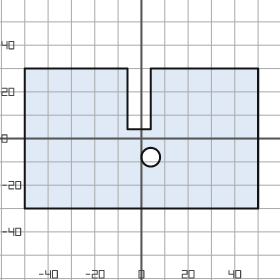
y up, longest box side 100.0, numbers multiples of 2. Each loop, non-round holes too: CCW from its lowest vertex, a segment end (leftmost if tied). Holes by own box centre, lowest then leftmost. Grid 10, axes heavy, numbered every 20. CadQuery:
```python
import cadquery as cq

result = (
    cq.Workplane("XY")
    .moveTo(-50.0, -30.0)
    .lineTo(50.0, -30.0)
    .lineTo(50.0, 30.0)
    .lineTo(4.0, 30.0)
    .lineTo(4.0, 4.0)
    .lineTo(-6.0, 4.0)
    .lineTo(-6.0, 30.0)
    .lineTo(-50.0, 30.0)
    .close()
    .moveTo(4.0, -8.0)
    .circle(4.0)
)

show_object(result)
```